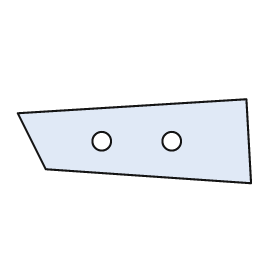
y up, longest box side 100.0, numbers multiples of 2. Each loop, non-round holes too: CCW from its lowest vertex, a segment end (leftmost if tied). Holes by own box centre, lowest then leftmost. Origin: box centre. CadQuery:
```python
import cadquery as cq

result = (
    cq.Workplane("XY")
    .moveTo(50.0, -18.0)
    .lineTo(48.0, 18.0)
    .lineTo(-50.0, 12.0)
    .lineTo(-38.0, -12.0)
    .close()
    .moveTo(-14.0, 0.0)
    .circle(4.0)
    .moveTo(16.0, 0.0)
    .circle(4.0)
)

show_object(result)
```